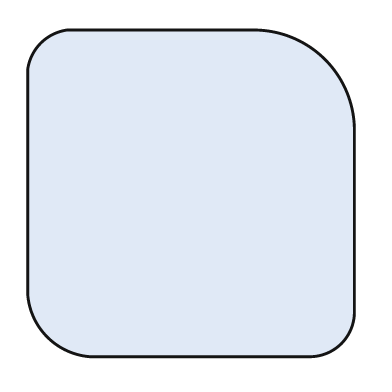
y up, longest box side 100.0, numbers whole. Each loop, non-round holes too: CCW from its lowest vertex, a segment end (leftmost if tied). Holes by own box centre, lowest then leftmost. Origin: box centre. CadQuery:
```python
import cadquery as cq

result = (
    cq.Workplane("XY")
    .moveTo(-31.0, -50.0)
    .lineTo(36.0, -50.0)
    .threePointArc((46.0, -46.0), (50.0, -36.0))
    .lineTo(50.0, 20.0)
    .threePointArc((41.0, 41.0), (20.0, 50.0))
    .lineTo(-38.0, 50.0)
    .threePointArc((-46.0, 46.0), (-50.0, 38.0))
    .lineTo(-50.0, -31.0)
    .threePointArc((-44.0, -44.0), (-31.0, -50.0))
    .close()
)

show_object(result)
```